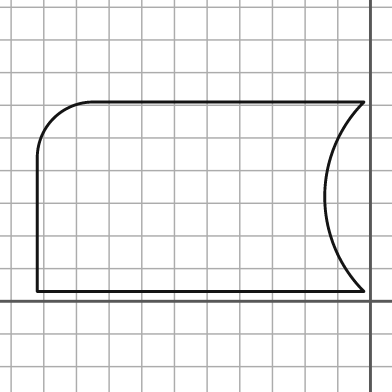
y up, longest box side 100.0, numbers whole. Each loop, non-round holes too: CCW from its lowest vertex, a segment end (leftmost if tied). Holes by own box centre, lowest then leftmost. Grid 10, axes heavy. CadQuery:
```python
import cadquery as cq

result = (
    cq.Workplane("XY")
    .moveTo(-102.0, 3.0)
    .lineTo(-2.0, 3.0)
    .threePointArc((-14.0, 32.0), (-2.0, 61.0))
    .lineTo(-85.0, 61.0)
    .threePointArc((-97.0, 56.0), (-102.0, 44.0))
    .close()
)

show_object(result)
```